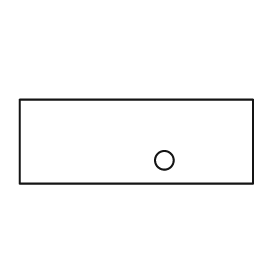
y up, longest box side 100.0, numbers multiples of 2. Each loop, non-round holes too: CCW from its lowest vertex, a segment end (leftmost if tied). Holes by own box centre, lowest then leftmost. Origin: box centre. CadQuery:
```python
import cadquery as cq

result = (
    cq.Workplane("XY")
    .moveTo(-50.0, -18.0)
    .lineTo(50.0, -18.0)
    .lineTo(50.0, 18.0)
    .lineTo(-50.0, 18.0)
    .close()
    .moveTo(12.0, -8.0)
    .circle(4.0)
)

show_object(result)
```